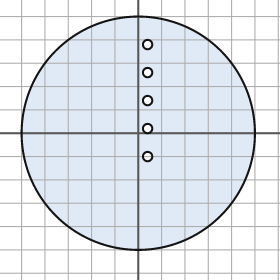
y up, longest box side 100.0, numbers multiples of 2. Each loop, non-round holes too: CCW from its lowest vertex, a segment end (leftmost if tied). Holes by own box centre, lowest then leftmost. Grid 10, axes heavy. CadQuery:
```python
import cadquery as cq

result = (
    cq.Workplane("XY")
    .moveTo(0.0, 0.0)
    .circle(50.0)
    .moveTo(4.0, -10.0)
    .circle(2.0)
    .moveTo(4.0, 2.0)
    .circle(2.0)
    .moveTo(4.0, 14.0)
    .circle(2.0)
    .moveTo(4.0, 26.0)
    .circle(2.0)
    .moveTo(4.0, 38.0)
    .circle(2.0)
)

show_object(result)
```